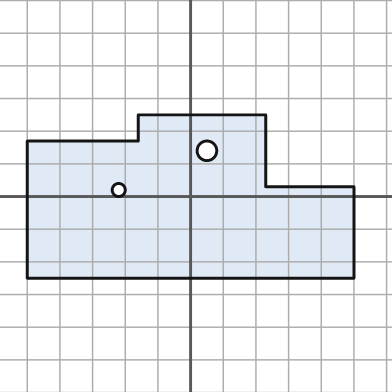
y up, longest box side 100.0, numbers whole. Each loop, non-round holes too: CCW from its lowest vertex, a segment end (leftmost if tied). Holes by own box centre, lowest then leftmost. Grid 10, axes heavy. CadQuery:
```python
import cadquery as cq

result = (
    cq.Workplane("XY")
    .moveTo(-50.0, -25.0)
    .lineTo(50.0, -25.0)
    .lineTo(50.0, 3.0)
    .lineTo(23.0, 3.0)
    .lineTo(23.0, 25.0)
    .lineTo(-16.0, 25.0)
    .lineTo(-16.0, 17.0)
    .lineTo(-50.0, 17.0)
    .close()
    .moveTo(-22.0, 2.0)
    .circle(2.0)
    .moveTo(5.0, 14.0)
    .circle(3.0)
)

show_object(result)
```